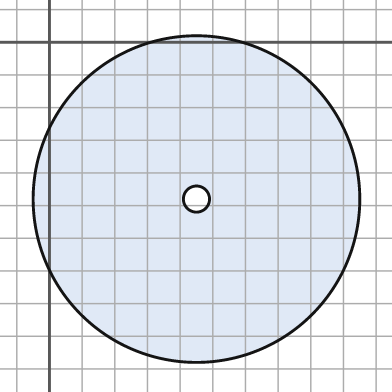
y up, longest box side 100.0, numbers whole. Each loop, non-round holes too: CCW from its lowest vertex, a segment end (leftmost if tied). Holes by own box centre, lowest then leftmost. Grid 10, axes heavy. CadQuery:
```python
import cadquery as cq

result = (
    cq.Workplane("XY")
    .moveTo(45.0, -48.0)
    .circle(50.0)
    .moveTo(45.0, -48.0)
    .circle(4.0)
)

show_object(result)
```